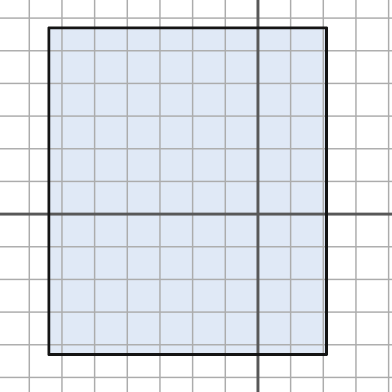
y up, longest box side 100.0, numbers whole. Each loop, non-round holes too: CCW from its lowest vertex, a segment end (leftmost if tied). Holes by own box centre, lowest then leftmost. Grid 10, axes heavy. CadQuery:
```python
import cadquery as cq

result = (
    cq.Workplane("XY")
    .moveTo(-64.0, -43.0)
    .lineTo(21.0, -43.0)
    .lineTo(21.0, 57.0)
    .lineTo(-64.0, 57.0)
    .close()
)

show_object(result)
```